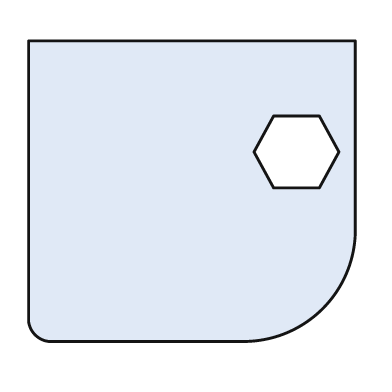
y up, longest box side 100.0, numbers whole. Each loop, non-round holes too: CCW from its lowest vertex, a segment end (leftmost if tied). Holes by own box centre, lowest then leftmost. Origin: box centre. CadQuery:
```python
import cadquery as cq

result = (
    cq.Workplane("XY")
    .moveTo(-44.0, -46.0)
    .lineTo(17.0, -46.0)
    .threePointArc((40.0, -36.0), (50.0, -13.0))
    .lineTo(50.0, 46.0)
    .lineTo(-50.0, 46.0)
    .lineTo(-50.0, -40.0)
    .threePointArc((-48.0, -44.0), (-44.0, -46.0))
    .close()
    .moveTo(25.0, 1.0)
    .lineTo(39.0, 1.0)
    .lineTo(45.0, 12.0)
    .lineTo(39.0, 23.0)
    .lineTo(25.0, 23.0)
    .lineTo(19.0, 12.0)
    .close()
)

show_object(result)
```